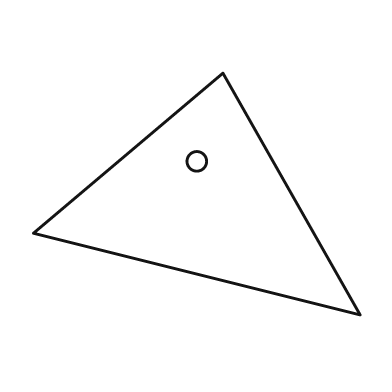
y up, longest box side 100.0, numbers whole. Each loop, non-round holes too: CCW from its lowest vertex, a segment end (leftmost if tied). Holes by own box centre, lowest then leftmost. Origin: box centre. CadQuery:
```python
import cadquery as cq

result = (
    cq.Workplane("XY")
    .moveTo(50.0, -37.0)
    .lineTo(8.0, 37.0)
    .lineTo(-50.0, -12.0)
    .close()
    .moveTo(0.0, 10.0)
    .circle(3.0)
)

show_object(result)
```